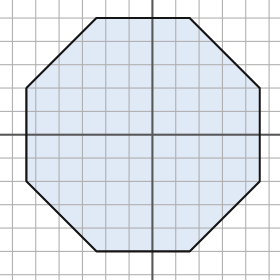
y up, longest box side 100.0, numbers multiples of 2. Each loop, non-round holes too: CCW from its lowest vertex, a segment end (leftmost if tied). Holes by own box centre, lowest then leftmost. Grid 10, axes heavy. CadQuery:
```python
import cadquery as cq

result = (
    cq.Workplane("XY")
    .moveTo(-24.0, -50.0)
    .lineTo(16.0, -50.0)
    .lineTo(46.0, -20.0)
    .lineTo(46.0, 20.0)
    .lineTo(16.0, 50.0)
    .lineTo(-24.0, 50.0)
    .lineTo(-54.0, 20.0)
    .lineTo(-54.0, -20.0)
    .close()
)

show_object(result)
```